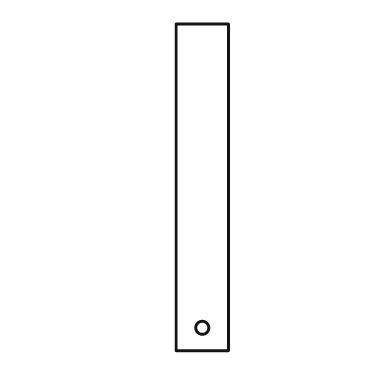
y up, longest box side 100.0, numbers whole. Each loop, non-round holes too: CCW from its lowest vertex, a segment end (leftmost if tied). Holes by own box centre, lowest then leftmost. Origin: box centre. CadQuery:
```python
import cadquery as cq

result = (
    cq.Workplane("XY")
    .moveTo(-8.0, -50.0)
    .lineTo(8.0, -50.0)
    .lineTo(8.0, 50.0)
    .lineTo(-8.0, 50.0)
    .close()
    .moveTo(0.0, -43.0)
    .circle(2.0)
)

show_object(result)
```